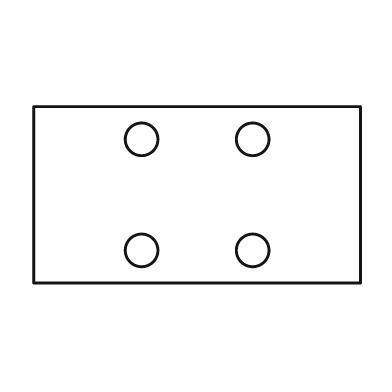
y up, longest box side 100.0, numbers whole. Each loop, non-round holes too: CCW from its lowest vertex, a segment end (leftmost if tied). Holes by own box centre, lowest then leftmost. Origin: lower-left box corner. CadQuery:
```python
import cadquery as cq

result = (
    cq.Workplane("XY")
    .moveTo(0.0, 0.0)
    .lineTo(100.0, 0.0)
    .lineTo(100.0, 54.0)
    .lineTo(0.0, 54.0)
    .close()
    .moveTo(33.0, 10.0)
    .circle(5.0)
    .moveTo(67.0, 10.0)
    .circle(5.0)
    .moveTo(33.0, 44.0)
    .circle(5.0)
    .moveTo(67.0, 44.0)
    .circle(5.0)
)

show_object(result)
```